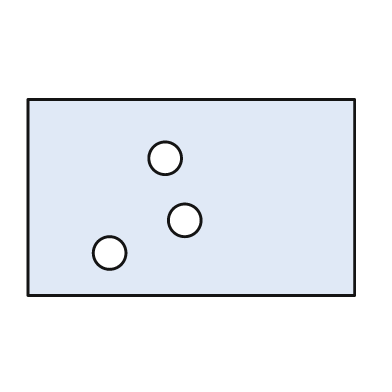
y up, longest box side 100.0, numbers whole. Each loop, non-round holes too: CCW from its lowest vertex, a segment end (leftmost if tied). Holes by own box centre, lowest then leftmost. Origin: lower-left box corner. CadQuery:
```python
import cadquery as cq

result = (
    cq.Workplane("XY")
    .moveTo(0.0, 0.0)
    .lineTo(100.0, 0.0)
    .lineTo(100.0, 60.0)
    .lineTo(0.0, 60.0)
    .close()
    .moveTo(25.0, 13.0)
    .circle(5.0)
    .moveTo(48.0, 23.0)
    .circle(5.0)
    .moveTo(42.0, 42.0)
    .circle(5.0)
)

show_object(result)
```